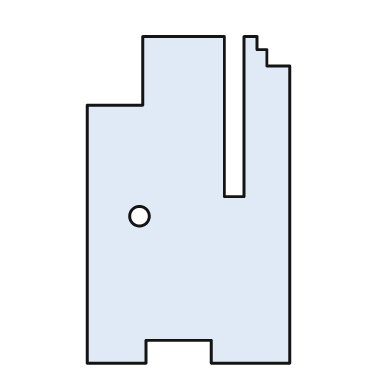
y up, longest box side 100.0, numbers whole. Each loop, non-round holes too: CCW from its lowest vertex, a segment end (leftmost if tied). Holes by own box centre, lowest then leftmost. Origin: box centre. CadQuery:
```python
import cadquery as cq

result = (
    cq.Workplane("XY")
    .moveTo(-31.0, -50.0)
    .lineTo(-13.0, -50.0)
    .lineTo(-13.0, -43.0)
    .lineTo(7.0, -43.0)
    .lineTo(7.0, -50.0)
    .lineTo(31.0, -50.0)
    .lineTo(31.0, 41.0)
    .lineTo(24.0, 41.0)
    .lineTo(24.0, 46.0)
    .lineTo(21.0, 46.0)
    .lineTo(21.0, 50.0)
    .lineTo(17.0, 50.0)
    .lineTo(17.0, 1.0)
    .lineTo(11.0, 1.0)
    .lineTo(11.0, 50.0)
    .lineTo(-14.0, 50.0)
    .lineTo(-14.0, 29.0)
    .lineTo(-31.0, 29.0)
    .close()
    .moveTo(-15.0, -5.0)
    .circle(3.0)
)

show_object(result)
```